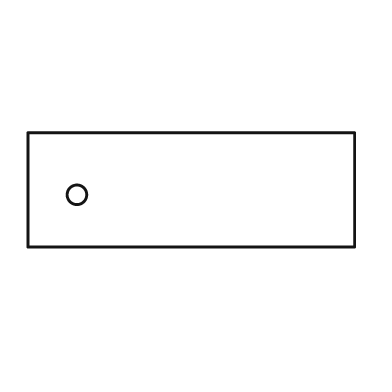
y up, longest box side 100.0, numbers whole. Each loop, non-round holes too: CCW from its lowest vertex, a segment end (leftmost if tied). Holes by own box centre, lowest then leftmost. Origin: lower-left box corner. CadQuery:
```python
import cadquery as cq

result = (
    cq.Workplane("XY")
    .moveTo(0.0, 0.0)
    .lineTo(100.0, 0.0)
    .lineTo(100.0, 35.0)
    .lineTo(0.0, 35.0)
    .close()
    .moveTo(15.0, 16.0)
    .circle(3.0)
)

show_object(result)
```